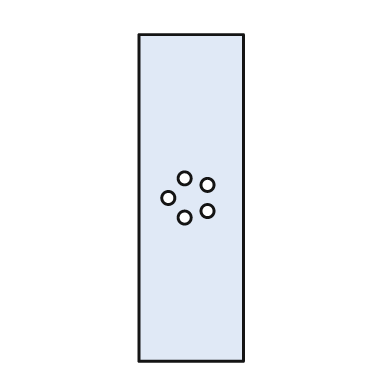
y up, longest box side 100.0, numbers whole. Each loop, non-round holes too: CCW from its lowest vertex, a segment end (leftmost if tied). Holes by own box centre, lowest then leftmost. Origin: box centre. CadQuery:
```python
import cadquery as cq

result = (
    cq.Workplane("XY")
    .moveTo(-16.0, -50.0)
    .lineTo(16.0, -50.0)
    .lineTo(16.0, 50.0)
    .lineTo(-16.0, 50.0)
    .close()
    .moveTo(-2.0, -6.0)
    .circle(2.0)
    .moveTo(5.0, -4.0)
    .circle(2.0)
    .moveTo(-7.0, 0.0)
    .circle(2.0)
    .moveTo(5.0, 4.0)
    .circle(2.0)
    .moveTo(-2.0, 6.0)
    .circle(2.0)
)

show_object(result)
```